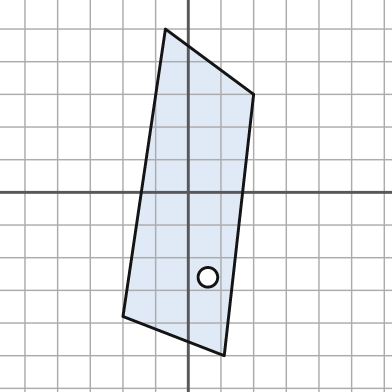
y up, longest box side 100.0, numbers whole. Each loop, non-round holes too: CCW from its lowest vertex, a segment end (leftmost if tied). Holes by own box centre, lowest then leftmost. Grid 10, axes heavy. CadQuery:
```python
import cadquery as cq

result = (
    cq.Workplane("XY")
    .moveTo(11.0, -50.0)
    .lineTo(20.0, 30.0)
    .lineTo(-7.0, 50.0)
    .lineTo(-20.0, -38.0)
    .close()
    .moveTo(6.0, -26.0)
    .circle(3.0)
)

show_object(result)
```